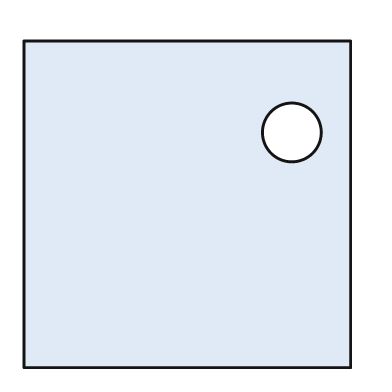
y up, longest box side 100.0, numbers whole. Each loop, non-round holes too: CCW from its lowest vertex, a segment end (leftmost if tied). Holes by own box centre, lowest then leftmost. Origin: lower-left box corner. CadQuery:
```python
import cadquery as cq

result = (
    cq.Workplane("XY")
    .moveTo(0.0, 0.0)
    .lineTo(100.0, 0.0)
    .lineTo(100.0, 100.0)
    .lineTo(0.0, 100.0)
    .close()
    .moveTo(82.0, 72.0)
    .circle(9.0)
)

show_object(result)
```